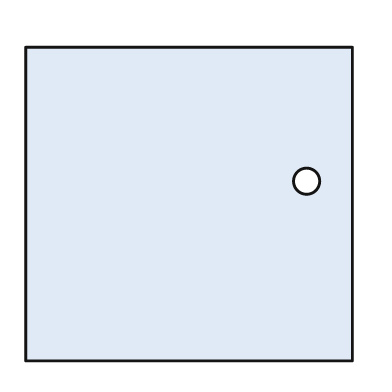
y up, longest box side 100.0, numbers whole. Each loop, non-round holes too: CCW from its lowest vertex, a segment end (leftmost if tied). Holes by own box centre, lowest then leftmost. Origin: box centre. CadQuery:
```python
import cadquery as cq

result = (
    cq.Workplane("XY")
    .moveTo(-50.0, -48.0)
    .lineTo(50.0, -48.0)
    .lineTo(50.0, 48.0)
    .lineTo(-50.0, 48.0)
    .close()
    .moveTo(36.0, 7.0)
    .circle(4.0)
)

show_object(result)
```